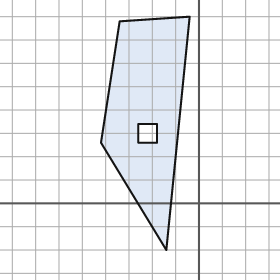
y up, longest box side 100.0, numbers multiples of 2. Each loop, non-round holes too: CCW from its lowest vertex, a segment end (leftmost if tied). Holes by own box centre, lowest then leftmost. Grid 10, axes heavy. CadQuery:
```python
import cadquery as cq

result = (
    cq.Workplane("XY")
    .moveTo(-14.0, -20.0)
    .lineTo(-4.0, 80.0)
    .lineTo(-34.0, 78.0)
    .lineTo(-42.0, 26.0)
    .close()
    .moveTo(-26.0, 26.0)
    .lineTo(-18.0, 26.0)
    .lineTo(-18.0, 34.0)
    .lineTo(-26.0, 34.0)
    .close()
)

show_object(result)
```